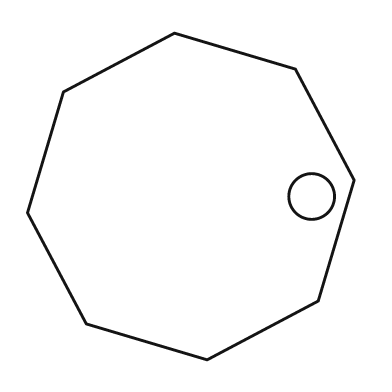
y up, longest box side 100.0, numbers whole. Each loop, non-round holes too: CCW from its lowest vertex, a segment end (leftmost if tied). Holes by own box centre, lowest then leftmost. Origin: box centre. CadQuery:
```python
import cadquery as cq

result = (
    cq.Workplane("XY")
    .moveTo(5.0, -50.0)
    .lineTo(39.0, -32.0)
    .lineTo(50.0, 5.0)
    .lineTo(32.0, 39.0)
    .lineTo(-5.0, 50.0)
    .lineTo(-39.0, 32.0)
    .lineTo(-50.0, -5.0)
    .lineTo(-32.0, -39.0)
    .close()
    .moveTo(37.0, 0.0)
    .circle(7.0)
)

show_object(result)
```